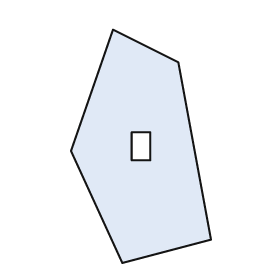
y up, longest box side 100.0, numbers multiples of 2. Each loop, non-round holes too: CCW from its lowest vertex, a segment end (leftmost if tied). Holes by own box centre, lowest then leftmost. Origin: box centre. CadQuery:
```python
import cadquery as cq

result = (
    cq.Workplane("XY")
    .moveTo(-8.0, -50.0)
    .lineTo(30.0, -40.0)
    .lineTo(16.0, 36.0)
    .lineTo(-12.0, 50.0)
    .lineTo(-30.0, -2.0)
    .close()
    .moveTo(-4.0, -6.0)
    .lineTo(4.0, -6.0)
    .lineTo(4.0, 6.0)
    .lineTo(-4.0, 6.0)
    .close()
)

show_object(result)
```